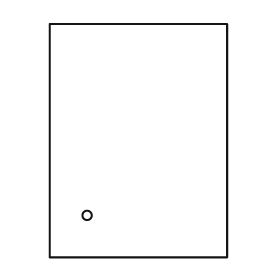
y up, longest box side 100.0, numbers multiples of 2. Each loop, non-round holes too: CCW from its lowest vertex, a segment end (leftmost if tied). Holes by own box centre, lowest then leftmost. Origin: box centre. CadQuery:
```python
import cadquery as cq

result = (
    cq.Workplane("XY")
    .moveTo(-38.0, -50.0)
    .lineTo(38.0, -50.0)
    .lineTo(38.0, 50.0)
    .lineTo(-38.0, 50.0)
    .close()
    .moveTo(-22.0, -32.0)
    .circle(2.0)
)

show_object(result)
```